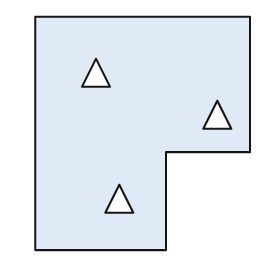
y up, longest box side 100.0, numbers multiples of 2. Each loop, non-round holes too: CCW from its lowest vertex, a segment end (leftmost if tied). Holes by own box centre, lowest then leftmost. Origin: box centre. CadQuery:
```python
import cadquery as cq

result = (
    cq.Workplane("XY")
    .moveTo(-46.0, -50.0)
    .lineTo(10.0, -50.0)
    .lineTo(10.0, -8.0)
    .lineTo(46.0, -8.0)
    .lineTo(46.0, 50.0)
    .lineTo(-46.0, 50.0)
    .close()
    .moveTo(-16.0, -34.0)
    .lineTo(-4.0, -34.0)
    .lineTo(-10.0, -22.0)
    .close()
    .moveTo(26.0, 2.0)
    .lineTo(38.0, 2.0)
    .lineTo(32.0, 14.0)
    .close()
    .moveTo(-26.0, 20.0)
    .lineTo(-14.0, 20.0)
    .lineTo(-20.0, 32.0)
    .close()
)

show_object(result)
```